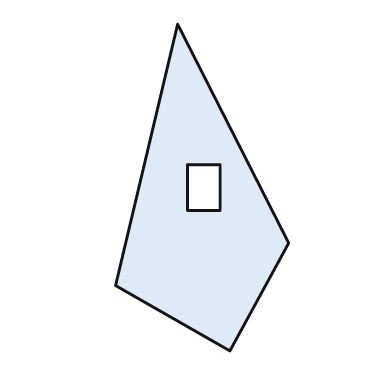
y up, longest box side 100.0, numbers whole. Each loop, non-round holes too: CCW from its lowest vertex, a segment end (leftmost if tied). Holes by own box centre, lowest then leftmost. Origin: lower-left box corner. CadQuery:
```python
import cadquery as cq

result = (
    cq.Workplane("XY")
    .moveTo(35.0, 0.0)
    .lineTo(53.0, 33.0)
    .lineTo(19.0, 100.0)
    .lineTo(0.0, 20.0)
    .close()
    .moveTo(22.0, 43.0)
    .lineTo(32.0, 43.0)
    .lineTo(32.0, 57.0)
    .lineTo(22.0, 57.0)
    .close()
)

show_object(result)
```